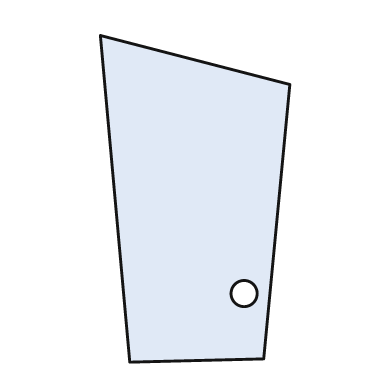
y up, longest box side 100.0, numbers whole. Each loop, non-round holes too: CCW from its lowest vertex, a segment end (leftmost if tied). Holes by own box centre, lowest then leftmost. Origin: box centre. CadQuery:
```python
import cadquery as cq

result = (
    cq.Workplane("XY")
    .moveTo(-20.0, -50.0)
    .lineTo(21.0, -49.0)
    .lineTo(29.0, 35.0)
    .lineTo(-29.0, 50.0)
    .close()
    .moveTo(15.0, -29.0)
    .circle(4.0)
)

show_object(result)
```